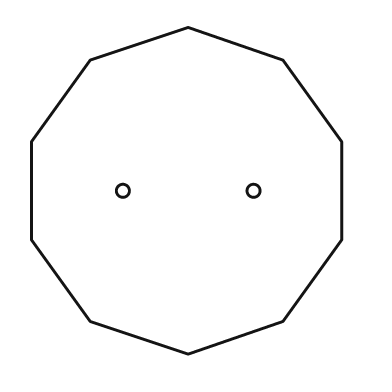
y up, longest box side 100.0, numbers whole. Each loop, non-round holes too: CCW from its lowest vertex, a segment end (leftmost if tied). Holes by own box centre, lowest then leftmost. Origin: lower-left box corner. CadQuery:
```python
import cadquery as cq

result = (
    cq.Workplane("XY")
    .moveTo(48.0, 0.0)
    .lineTo(77.0, 10.0)
    .lineTo(95.0, 35.0)
    .lineTo(95.0, 65.0)
    .lineTo(77.0, 90.0)
    .lineTo(48.0, 100.0)
    .lineTo(18.0, 90.0)
    .lineTo(0.0, 65.0)
    .lineTo(0.0, 35.0)
    .lineTo(18.0, 10.0)
    .close()
    .moveTo(28.0, 50.0)
    .circle(2.0)
    .moveTo(68.0, 50.0)
    .circle(2.0)
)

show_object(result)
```